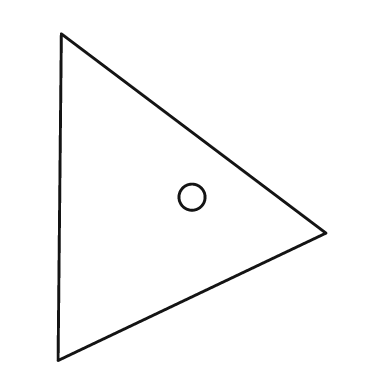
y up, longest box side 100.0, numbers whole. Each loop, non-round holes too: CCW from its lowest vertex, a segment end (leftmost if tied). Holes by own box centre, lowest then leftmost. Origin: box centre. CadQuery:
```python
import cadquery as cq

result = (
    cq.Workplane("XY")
    .moveTo(-41.0, -50.0)
    .lineTo(41.0, -11.0)
    .lineTo(-40.0, 50.0)
    .close()
    .moveTo(0.0, 0.0)
    .circle(4.0)
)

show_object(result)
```